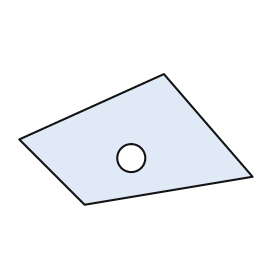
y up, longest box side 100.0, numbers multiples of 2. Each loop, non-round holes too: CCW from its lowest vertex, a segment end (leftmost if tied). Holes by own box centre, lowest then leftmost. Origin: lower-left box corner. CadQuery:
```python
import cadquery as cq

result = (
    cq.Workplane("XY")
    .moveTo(28.0, 0.0)
    .lineTo(100.0, 12.0)
    .lineTo(62.0, 56.0)
    .lineTo(0.0, 28.0)
    .close()
    .moveTo(48.0, 20.0)
    .circle(6.0)
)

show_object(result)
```